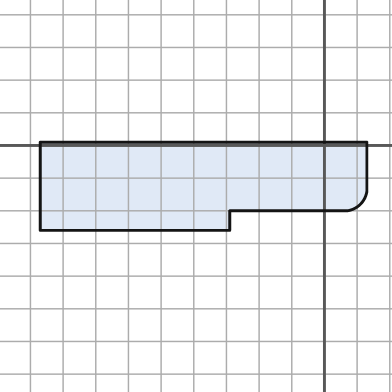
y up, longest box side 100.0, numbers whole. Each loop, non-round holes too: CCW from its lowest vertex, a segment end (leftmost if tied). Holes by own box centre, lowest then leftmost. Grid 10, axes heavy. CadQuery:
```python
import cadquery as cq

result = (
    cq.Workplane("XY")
    .moveTo(-87.0, -26.0)
    .lineTo(-29.0, -26.0)
    .lineTo(-29.0, -20.0)
    .lineTo(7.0, -20.0)
    .threePointArc((11.0, -18.0), (13.0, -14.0))
    .lineTo(13.0, 1.0)
    .lineTo(-87.0, 1.0)
    .close()
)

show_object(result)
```